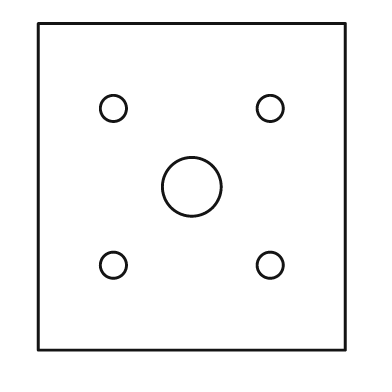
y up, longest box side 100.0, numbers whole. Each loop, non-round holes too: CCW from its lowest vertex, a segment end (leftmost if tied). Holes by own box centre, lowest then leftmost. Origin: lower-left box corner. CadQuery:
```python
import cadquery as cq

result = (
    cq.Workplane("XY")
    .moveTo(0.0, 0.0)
    .lineTo(94.0, 0.0)
    .lineTo(94.0, 100.0)
    .lineTo(0.0, 100.0)
    .close()
    .moveTo(23.0, 26.0)
    .circle(4.0)
    .moveTo(71.0, 26.0)
    .circle(4.0)
    .moveTo(47.0, 50.0)
    .circle(9.0)
    .moveTo(23.0, 74.0)
    .circle(4.0)
    .moveTo(71.0, 74.0)
    .circle(4.0)
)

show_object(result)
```